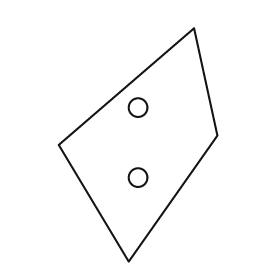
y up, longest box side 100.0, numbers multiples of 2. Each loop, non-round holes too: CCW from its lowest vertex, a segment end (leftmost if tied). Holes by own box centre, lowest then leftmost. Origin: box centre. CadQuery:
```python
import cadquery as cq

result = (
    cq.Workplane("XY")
    .moveTo(-4.0, -50.0)
    .lineTo(34.0, 4.0)
    .lineTo(24.0, 50.0)
    .lineTo(-34.0, 0.0)
    .close()
    .moveTo(0.0, -14.0)
    .circle(4.0)
    .moveTo(0.0, 16.0)
    .circle(4.0)
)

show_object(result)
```